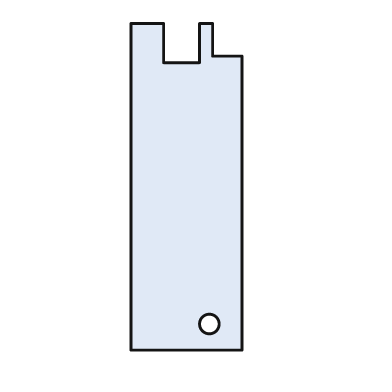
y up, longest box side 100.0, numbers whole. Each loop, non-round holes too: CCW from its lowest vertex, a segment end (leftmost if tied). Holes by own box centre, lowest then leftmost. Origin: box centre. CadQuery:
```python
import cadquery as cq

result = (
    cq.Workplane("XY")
    .moveTo(-17.0, -50.0)
    .lineTo(17.0, -50.0)
    .lineTo(17.0, 40.0)
    .lineTo(8.0, 40.0)
    .lineTo(8.0, 50.0)
    .lineTo(4.0, 50.0)
    .lineTo(4.0, 38.0)
    .lineTo(-7.0, 38.0)
    .lineTo(-7.0, 50.0)
    .lineTo(-17.0, 50.0)
    .close()
    .moveTo(7.0, -42.0)
    .circle(3.0)
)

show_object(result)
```